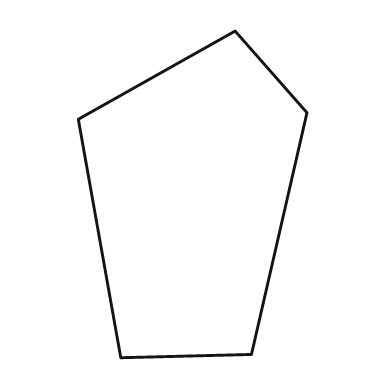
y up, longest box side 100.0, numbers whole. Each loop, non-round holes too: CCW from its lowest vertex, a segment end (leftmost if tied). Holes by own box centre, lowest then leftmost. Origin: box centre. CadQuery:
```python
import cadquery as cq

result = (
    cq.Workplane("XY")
    .moveTo(-22.0, -50.0)
    .lineTo(18.0, -49.0)
    .lineTo(35.0, 25.0)
    .lineTo(13.0, 50.0)
    .lineTo(-35.0, 23.0)
    .close()
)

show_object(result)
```